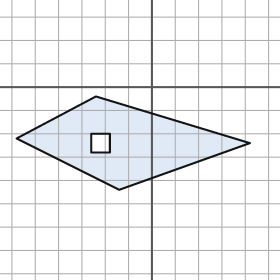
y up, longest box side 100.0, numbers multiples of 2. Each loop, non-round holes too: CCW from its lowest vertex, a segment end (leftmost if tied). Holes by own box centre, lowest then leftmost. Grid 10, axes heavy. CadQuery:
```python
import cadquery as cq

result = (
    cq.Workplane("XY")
    .moveTo(-14.0, -44.0)
    .lineTo(42.0, -24.0)
    .lineTo(-24.0, -4.0)
    .lineTo(-58.0, -22.0)
    .close()
    .moveTo(-26.0, -28.0)
    .lineTo(-18.0, -28.0)
    .lineTo(-18.0, -20.0)
    .lineTo(-26.0, -20.0)
    .close()
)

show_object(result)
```